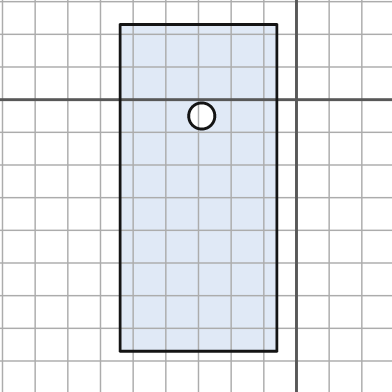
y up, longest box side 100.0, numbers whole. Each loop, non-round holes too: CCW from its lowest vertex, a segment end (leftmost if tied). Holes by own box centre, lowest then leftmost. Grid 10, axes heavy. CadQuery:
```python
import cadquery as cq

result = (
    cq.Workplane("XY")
    .moveTo(-54.0, -77.0)
    .lineTo(-6.0, -77.0)
    .lineTo(-6.0, 23.0)
    .lineTo(-54.0, 23.0)
    .close()
    .moveTo(-29.0, -5.0)
    .circle(4.0)
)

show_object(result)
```